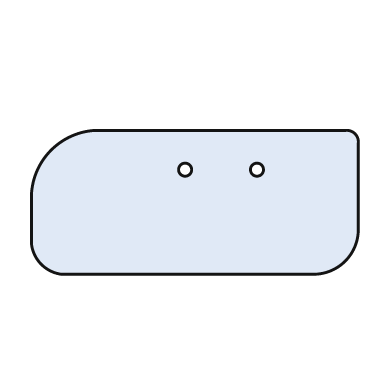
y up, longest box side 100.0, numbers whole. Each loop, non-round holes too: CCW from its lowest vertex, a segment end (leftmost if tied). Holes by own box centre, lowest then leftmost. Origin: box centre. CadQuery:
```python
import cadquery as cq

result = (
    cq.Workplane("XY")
    .moveTo(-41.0, -22.0)
    .lineTo(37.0, -22.0)
    .threePointArc((46.0, -18.0), (50.0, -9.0))
    .lineTo(50.0, 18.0)
    .threePointArc((49.0, 21.0), (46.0, 22.0))
    .lineTo(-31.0, 22.0)
    .threePointArc((-44.0, 16.0), (-50.0, 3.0))
    .lineTo(-50.0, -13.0)
    .threePointArc((-47.0, -19.0), (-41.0, -22.0))
    .close()
    .moveTo(-3.0, 10.0)
    .circle(2.0)
    .moveTo(19.0, 10.0)
    .circle(2.0)
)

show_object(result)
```